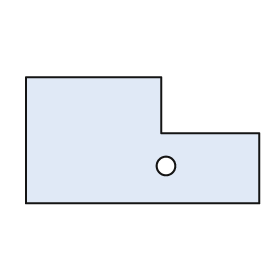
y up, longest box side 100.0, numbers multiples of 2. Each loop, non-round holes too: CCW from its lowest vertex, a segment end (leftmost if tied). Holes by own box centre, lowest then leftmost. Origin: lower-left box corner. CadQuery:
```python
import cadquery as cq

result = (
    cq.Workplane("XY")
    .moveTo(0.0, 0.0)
    .lineTo(100.0, 0.0)
    .lineTo(100.0, 30.0)
    .lineTo(58.0, 30.0)
    .lineTo(58.0, 54.0)
    .lineTo(0.0, 54.0)
    .close()
    .moveTo(60.0, 16.0)
    .circle(4.0)
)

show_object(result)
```